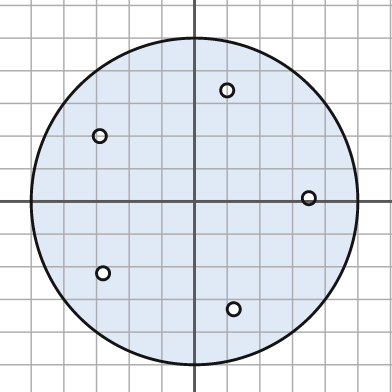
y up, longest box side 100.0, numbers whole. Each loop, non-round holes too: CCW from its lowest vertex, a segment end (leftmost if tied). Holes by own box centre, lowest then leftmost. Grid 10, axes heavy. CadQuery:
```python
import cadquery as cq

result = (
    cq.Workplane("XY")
    .moveTo(0.0, 0.0)
    .circle(50.0)
    .moveTo(12.0, -33.0)
    .circle(2.0)
    .moveTo(-28.0, -22.0)
    .circle(2.0)
    .moveTo(35.0, 1.0)
    .circle(2.0)
    .moveTo(-29.0, 20.0)
    .circle(2.0)
    .moveTo(10.0, 34.0)
    .circle(2.0)
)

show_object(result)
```